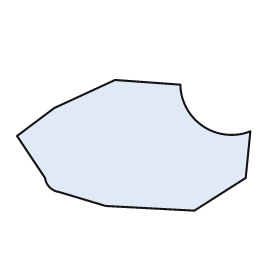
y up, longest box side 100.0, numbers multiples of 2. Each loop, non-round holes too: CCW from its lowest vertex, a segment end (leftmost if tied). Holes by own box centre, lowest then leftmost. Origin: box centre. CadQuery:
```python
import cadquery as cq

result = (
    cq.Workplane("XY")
    .moveTo(26.0, -28.0)
    .lineTo(48.0, -14.0)
    .lineTo(50.0, 6.0)
    .threePointArc((30.0, 8.0), (20.0, 26.0))
    .lineTo(-8.0, 28.0)
    .lineTo(-34.0, 16.0)
    .lineTo(-50.0, 4.0)
    .lineTo(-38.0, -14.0)
    .threePointArc((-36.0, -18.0), (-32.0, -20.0))
    .lineTo(-12.0, -26.0)
    .close()
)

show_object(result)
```